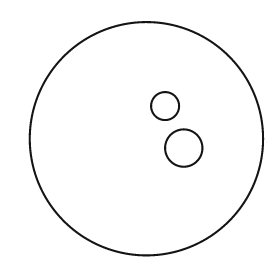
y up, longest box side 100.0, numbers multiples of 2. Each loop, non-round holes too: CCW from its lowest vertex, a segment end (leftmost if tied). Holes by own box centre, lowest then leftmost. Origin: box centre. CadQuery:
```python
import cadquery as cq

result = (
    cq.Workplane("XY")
    .moveTo(0.0, 0.0)
    .circle(50.0)
    .moveTo(16.0, -4.0)
    .circle(8.0)
    .moveTo(8.0, 14.0)
    .circle(6.0)
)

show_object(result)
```